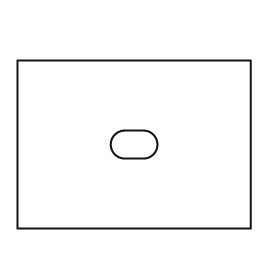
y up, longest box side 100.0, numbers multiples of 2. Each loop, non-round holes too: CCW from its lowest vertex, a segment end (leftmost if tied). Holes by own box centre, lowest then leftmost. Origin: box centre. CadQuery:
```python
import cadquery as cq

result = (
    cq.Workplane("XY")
    .moveTo(-50.0, -36.0)
    .lineTo(50.0, -36.0)
    .lineTo(50.0, 36.0)
    .lineTo(-50.0, 36.0)
    .close()
    .moveTo(-4.0, -6.0)
    .lineTo(4.0, -6.0)
    .threePointArc((10.0, 0.0), (4.0, 6.0))
    .lineTo(-4.0, 6.0)
    .threePointArc((-10.0, 0.0), (-4.0, -6.0))
    .close()
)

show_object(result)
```